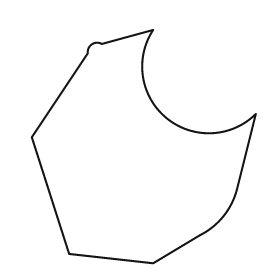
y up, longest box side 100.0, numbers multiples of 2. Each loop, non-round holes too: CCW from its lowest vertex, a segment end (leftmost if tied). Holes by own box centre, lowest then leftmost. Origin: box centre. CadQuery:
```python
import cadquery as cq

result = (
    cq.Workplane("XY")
    .moveTo(4.0, -50.0)
    .lineTo(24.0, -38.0)
    .threePointArc((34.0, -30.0), (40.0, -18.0))
    .lineTo(48.0, 14.0)
    .threePointArc((10.0, 12.0), (4.0, 50.0))
    .lineTo(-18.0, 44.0)
    .threePointArc((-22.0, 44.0), (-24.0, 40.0))
    .lineTo(-48.0, 4.0)
    .lineTo(-32.0, -46.0)
    .close()
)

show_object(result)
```